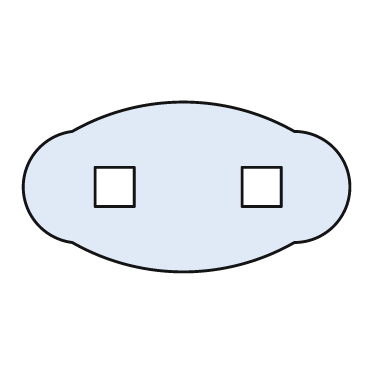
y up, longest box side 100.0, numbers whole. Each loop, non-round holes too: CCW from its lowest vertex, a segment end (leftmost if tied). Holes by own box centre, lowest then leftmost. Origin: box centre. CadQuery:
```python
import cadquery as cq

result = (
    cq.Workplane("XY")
    .moveTo(-35.0, -17.0)
    .threePointArc((-1.0, -26.0), (33.0, -17.0))
    .threePointArc((50.0, 0.0), (33.0, 17.0))
    .threePointArc((-1.0, 26.0), (-35.0, 17.0))
    .threePointArc((-50.0, 0.0), (-35.0, -17.0))
    .close()
    .moveTo(-28.0, -6.0)
    .lineTo(-16.0, -6.0)
    .lineTo(-16.0, 6.0)
    .lineTo(-28.0, 6.0)
    .close()
    .moveTo(17.0, -6.0)
    .lineTo(29.0, -6.0)
    .lineTo(29.0, 6.0)
    .lineTo(17.0, 6.0)
    .close()
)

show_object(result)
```